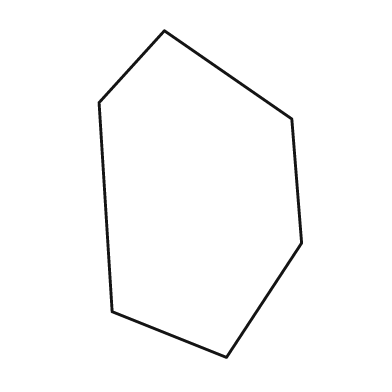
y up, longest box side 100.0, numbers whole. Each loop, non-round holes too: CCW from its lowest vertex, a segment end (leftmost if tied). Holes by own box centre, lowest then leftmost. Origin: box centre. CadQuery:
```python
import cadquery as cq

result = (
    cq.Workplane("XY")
    .moveTo(8.0, -50.0)
    .lineTo(31.0, -15.0)
    .lineTo(28.0, 23.0)
    .lineTo(-11.0, 50.0)
    .lineTo(-31.0, 28.0)
    .lineTo(-27.0, -36.0)
    .close()
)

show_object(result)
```